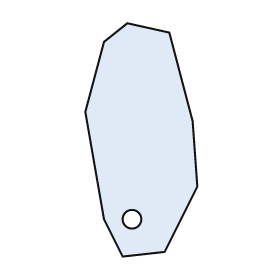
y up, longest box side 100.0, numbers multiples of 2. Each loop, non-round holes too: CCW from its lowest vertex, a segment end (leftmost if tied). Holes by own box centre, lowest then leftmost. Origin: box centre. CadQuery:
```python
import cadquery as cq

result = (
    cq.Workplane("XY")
    .moveTo(-8.0, -50.0)
    .lineTo(10.0, -48.0)
    .lineTo(24.0, -20.0)
    .lineTo(22.0, 8.0)
    .lineTo(12.0, 46.0)
    .lineTo(-6.0, 50.0)
    .lineTo(-16.0, 42.0)
    .lineTo(-24.0, 12.0)
    .lineTo(-16.0, -34.0)
    .close()
    .moveTo(-4.0, -34.0)
    .circle(4.0)
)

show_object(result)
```